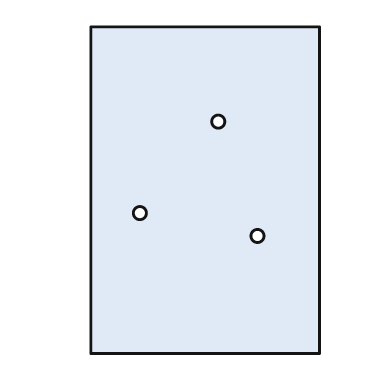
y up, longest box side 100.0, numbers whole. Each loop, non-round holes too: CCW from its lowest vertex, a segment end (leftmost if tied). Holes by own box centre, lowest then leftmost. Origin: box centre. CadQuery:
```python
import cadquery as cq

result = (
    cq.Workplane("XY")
    .moveTo(-35.0, -50.0)
    .lineTo(35.0, -50.0)
    .lineTo(35.0, 50.0)
    .lineTo(-35.0, 50.0)
    .close()
    .moveTo(16.0, -14.0)
    .circle(2.0)
    .moveTo(-20.0, -7.0)
    .circle(2.0)
    .moveTo(4.0, 21.0)
    .circle(2.0)
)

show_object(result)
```